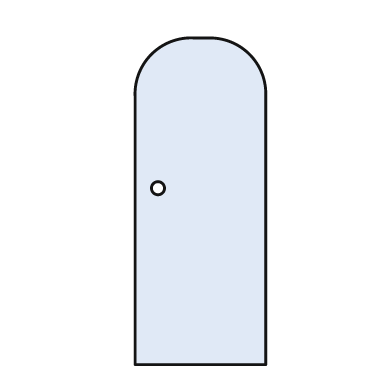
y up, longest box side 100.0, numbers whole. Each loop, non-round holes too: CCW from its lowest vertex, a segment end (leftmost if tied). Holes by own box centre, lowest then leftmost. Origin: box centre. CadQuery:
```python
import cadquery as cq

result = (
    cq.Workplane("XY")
    .moveTo(-20.0, -50.0)
    .lineTo(20.0, -50.0)
    .lineTo(20.0, 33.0)
    .threePointArc((15.0, 45.0), (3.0, 50.0))
    .lineTo(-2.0, 50.0)
    .threePointArc((-15.0, 45.0), (-20.0, 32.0))
    .close()
    .moveTo(-13.0, 4.0)
    .circle(2.0)
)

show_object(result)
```